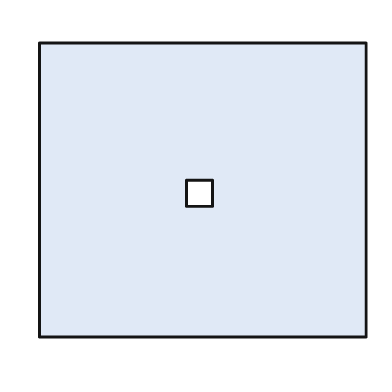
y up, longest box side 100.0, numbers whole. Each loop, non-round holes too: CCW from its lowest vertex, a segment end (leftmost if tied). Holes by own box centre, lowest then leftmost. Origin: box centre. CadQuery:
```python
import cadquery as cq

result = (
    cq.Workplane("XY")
    .moveTo(-50.0, -45.0)
    .lineTo(50.0, -45.0)
    .lineTo(50.0, 45.0)
    .lineTo(-50.0, 45.0)
    .close()
    .moveTo(-5.0, -5.0)
    .lineTo(3.0, -5.0)
    .lineTo(3.0, 3.0)
    .lineTo(-5.0, 3.0)
    .close()
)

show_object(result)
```